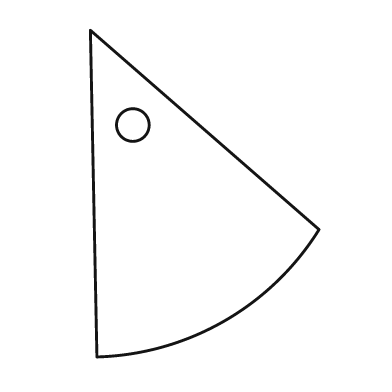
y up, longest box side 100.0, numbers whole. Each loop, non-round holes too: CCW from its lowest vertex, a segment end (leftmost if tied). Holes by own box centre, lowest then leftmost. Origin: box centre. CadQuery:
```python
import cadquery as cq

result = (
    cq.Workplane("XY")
    .moveTo(-33.0, -50.0)
    .threePointArc((6.0, -39.0), (35.0, -11.0))
    .lineTo(-35.0, 50.0)
    .close()
    .moveTo(-22.0, 21.0)
    .circle(5.0)
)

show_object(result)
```